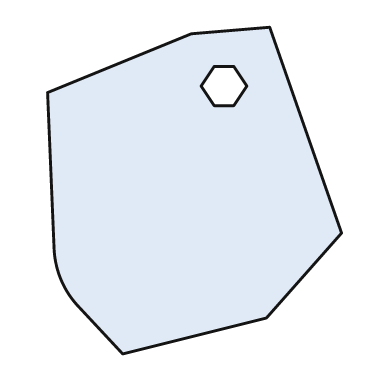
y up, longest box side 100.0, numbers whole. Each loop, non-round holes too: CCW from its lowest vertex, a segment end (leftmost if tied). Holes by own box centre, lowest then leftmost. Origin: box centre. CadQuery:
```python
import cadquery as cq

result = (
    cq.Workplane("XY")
    .moveTo(-22.0, -50.0)
    .lineTo(22.0, -39.0)
    .lineTo(45.0, -13.0)
    .lineTo(23.0, 50.0)
    .lineTo(-1.0, 48.0)
    .lineTo(-45.0, 30.0)
    .lineTo(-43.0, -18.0)
    .threePointArc((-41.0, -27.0), (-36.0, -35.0))
    .close()
    .moveTo(6.0, 26.0)
    .lineTo(12.0, 26.0)
    .lineTo(16.0, 32.0)
    .lineTo(12.0, 38.0)
    .lineTo(6.0, 38.0)
    .lineTo(2.0, 32.0)
    .close()
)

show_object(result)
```